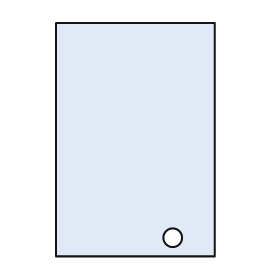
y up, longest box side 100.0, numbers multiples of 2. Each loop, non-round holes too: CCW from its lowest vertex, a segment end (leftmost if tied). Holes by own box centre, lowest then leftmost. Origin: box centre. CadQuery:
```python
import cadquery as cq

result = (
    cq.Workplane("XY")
    .moveTo(-34.0, -50.0)
    .lineTo(34.0, -50.0)
    .lineTo(34.0, 50.0)
    .lineTo(-34.0, 50.0)
    .close()
    .moveTo(16.0, -42.0)
    .circle(4.0)
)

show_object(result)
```